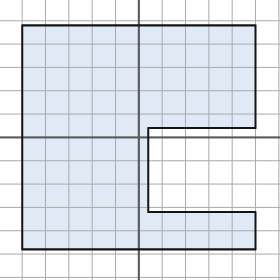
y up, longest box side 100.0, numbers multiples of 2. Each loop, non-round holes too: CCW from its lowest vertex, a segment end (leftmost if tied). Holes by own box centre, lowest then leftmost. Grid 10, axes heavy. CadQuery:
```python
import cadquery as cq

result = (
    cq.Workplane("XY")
    .moveTo(-50.0, -48.0)
    .lineTo(50.0, -48.0)
    .lineTo(50.0, -32.0)
    .lineTo(4.0, -32.0)
    .lineTo(4.0, 4.0)
    .lineTo(50.0, 4.0)
    .lineTo(50.0, 48.0)
    .lineTo(-50.0, 48.0)
    .close()
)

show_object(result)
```